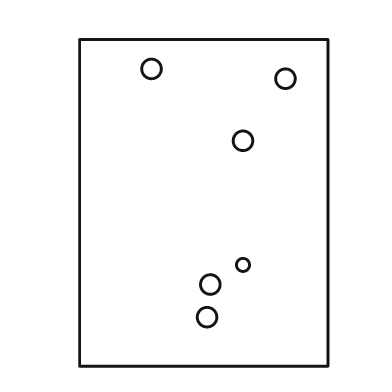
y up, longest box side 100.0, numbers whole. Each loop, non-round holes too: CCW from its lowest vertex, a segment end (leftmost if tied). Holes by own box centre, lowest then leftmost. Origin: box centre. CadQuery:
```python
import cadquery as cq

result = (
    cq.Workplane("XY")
    .moveTo(-38.0, -50.0)
    .lineTo(38.0, -50.0)
    .lineTo(38.0, 50.0)
    .lineTo(-38.0, 50.0)
    .close()
    .moveTo(1.0, -35.0)
    .circle(3.0)
    .moveTo(2.0, -25.0)
    .circle(3.0)
    .moveTo(12.0, -19.0)
    .circle(2.0)
    .moveTo(12.0, 19.0)
    .circle(3.0)
    .moveTo(25.0, 38.0)
    .circle(3.0)
    .moveTo(-16.0, 41.0)
    .circle(3.0)
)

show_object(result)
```